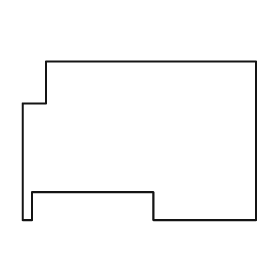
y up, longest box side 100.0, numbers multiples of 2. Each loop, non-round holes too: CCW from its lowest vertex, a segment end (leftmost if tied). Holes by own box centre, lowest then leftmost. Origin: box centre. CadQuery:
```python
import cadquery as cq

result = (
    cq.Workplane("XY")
    .moveTo(-50.0, -34.0)
    .lineTo(-46.0, -34.0)
    .lineTo(-46.0, -22.0)
    .lineTo(6.0, -22.0)
    .lineTo(6.0, -34.0)
    .lineTo(50.0, -34.0)
    .lineTo(50.0, 34.0)
    .lineTo(-40.0, 34.0)
    .lineTo(-40.0, 16.0)
    .lineTo(-50.0, 16.0)
    .close()
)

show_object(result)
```